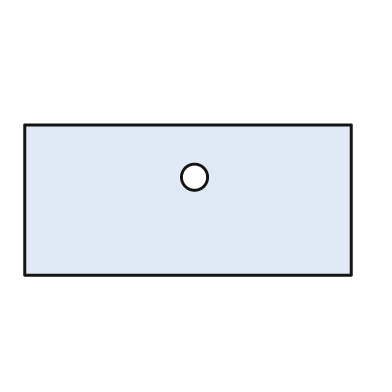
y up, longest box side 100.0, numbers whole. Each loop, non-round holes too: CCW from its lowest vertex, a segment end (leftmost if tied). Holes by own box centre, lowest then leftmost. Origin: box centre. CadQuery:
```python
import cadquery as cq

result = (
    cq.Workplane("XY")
    .moveTo(-50.0, -23.0)
    .lineTo(50.0, -23.0)
    .lineTo(50.0, 23.0)
    .lineTo(-50.0, 23.0)
    .close()
    .moveTo(2.0, 7.0)
    .circle(4.0)
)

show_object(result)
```